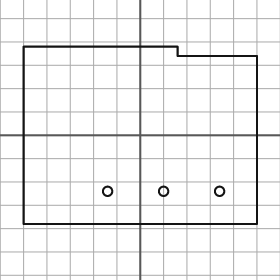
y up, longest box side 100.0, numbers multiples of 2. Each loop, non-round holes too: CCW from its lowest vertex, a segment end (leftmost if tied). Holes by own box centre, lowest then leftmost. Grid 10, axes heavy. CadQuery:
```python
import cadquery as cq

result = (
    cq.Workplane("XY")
    .moveTo(-50.0, -38.0)
    .lineTo(50.0, -38.0)
    .lineTo(50.0, 34.0)
    .lineTo(16.0, 34.0)
    .lineTo(16.0, 38.0)
    .lineTo(-50.0, 38.0)
    .close()
    .moveTo(-14.0, -24.0)
    .circle(2.0)
    .moveTo(10.0, -24.0)
    .circle(2.0)
    .moveTo(34.0, -24.0)
    .circle(2.0)
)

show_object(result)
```